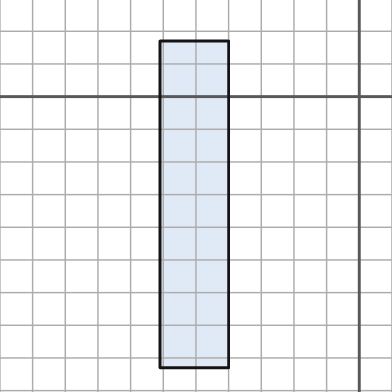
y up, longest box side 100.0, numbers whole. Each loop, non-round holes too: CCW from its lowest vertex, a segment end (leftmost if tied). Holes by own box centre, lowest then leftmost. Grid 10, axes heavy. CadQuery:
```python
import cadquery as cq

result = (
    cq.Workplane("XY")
    .moveTo(-61.0, -83.0)
    .lineTo(-40.0, -83.0)
    .lineTo(-40.0, 17.0)
    .lineTo(-61.0, 17.0)
    .close()
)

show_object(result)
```